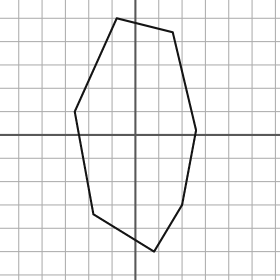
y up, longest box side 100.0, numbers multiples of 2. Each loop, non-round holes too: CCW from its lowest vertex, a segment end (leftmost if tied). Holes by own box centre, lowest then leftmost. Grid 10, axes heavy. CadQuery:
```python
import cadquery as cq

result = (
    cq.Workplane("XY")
    .moveTo(8.0, -50.0)
    .lineTo(20.0, -30.0)
    .lineTo(26.0, 2.0)
    .lineTo(16.0, 44.0)
    .lineTo(-8.0, 50.0)
    .lineTo(-26.0, 10.0)
    .lineTo(-18.0, -34.0)
    .close()
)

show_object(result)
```